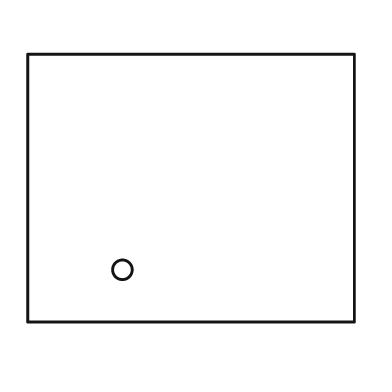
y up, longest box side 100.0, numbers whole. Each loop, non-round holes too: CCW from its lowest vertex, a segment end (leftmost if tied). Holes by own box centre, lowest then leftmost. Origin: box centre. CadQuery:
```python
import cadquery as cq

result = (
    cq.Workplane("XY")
    .moveTo(-50.0, -41.0)
    .lineTo(50.0, -41.0)
    .lineTo(50.0, 41.0)
    .lineTo(-50.0, 41.0)
    .close()
    .moveTo(-21.0, -25.0)
    .circle(3.0)
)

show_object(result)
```